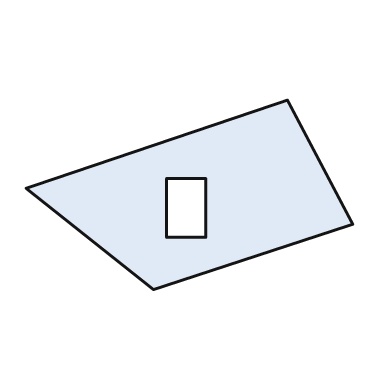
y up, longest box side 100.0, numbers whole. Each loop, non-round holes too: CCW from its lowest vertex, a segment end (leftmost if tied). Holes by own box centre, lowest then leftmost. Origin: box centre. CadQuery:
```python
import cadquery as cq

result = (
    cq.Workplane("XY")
    .moveTo(-11.0, -29.0)
    .lineTo(50.0, -9.0)
    .lineTo(30.0, 29.0)
    .lineTo(-50.0, 2.0)
    .close()
    .moveTo(-7.0, -13.0)
    .lineTo(5.0, -13.0)
    .lineTo(5.0, 5.0)
    .lineTo(-7.0, 5.0)
    .close()
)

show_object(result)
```